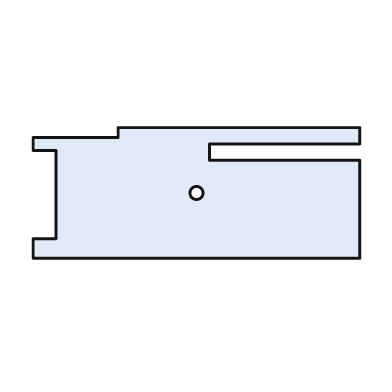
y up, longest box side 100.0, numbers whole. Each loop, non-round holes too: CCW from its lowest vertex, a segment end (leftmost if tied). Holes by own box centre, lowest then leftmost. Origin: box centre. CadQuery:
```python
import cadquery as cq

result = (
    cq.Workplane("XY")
    .moveTo(-50.0, -20.0)
    .lineTo(50.0, -20.0)
    .lineTo(50.0, 10.0)
    .lineTo(4.0, 10.0)
    .lineTo(4.0, 15.0)
    .lineTo(50.0, 15.0)
    .lineTo(50.0, 20.0)
    .lineTo(-24.0, 20.0)
    .lineTo(-24.0, 17.0)
    .lineTo(-50.0, 17.0)
    .lineTo(-50.0, 13.0)
    .lineTo(-43.0, 13.0)
    .lineTo(-43.0, -14.0)
    .lineTo(-50.0, -14.0)
    .close()
    .moveTo(0.0, 0.0)
    .circle(2.0)
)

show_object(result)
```